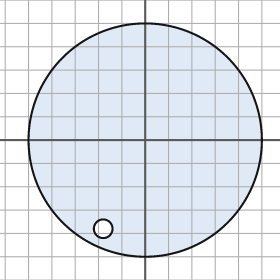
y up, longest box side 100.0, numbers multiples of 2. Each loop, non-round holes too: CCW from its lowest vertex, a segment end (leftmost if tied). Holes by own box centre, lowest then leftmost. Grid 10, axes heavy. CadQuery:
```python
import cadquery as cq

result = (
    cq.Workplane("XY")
    .moveTo(0.0, 0.0)
    .circle(50.0)
    .moveTo(-18.0, -38.0)
    .circle(4.0)
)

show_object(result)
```